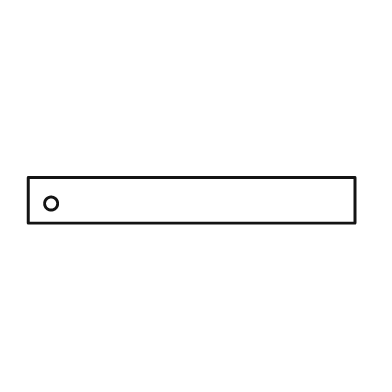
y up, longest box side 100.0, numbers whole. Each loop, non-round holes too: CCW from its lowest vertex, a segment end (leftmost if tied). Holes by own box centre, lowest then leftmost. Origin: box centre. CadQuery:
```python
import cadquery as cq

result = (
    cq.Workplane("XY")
    .moveTo(-50.0, -7.0)
    .lineTo(50.0, -7.0)
    .lineTo(50.0, 7.0)
    .lineTo(-50.0, 7.0)
    .close()
    .moveTo(-43.0, -1.0)
    .circle(2.0)
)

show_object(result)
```